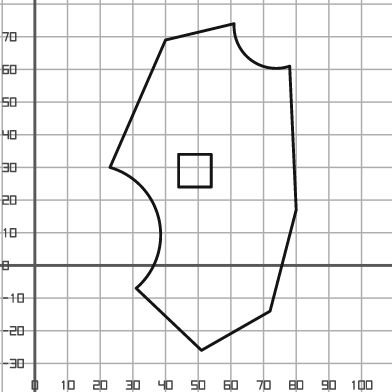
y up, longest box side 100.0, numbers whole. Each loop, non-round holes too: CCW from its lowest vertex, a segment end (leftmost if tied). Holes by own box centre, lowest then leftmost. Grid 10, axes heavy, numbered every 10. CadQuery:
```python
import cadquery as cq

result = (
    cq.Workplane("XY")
    .moveTo(51.0, -26.0)
    .lineTo(72.0, -14.0)
    .lineTo(80.0, 17.0)
    .lineTo(78.0, 61.0)
    .threePointArc((66.0, 63.0), (61.0, 74.0))
    .lineTo(40.0, 69.0)
    .lineTo(23.0, 30.0)
    .threePointArc((38.0, 14.0), (31.0, -7.0))
    .close()
    .moveTo(44.0, 24.0)
    .lineTo(54.0, 24.0)
    .lineTo(54.0, 34.0)
    .lineTo(44.0, 34.0)
    .close()
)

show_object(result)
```